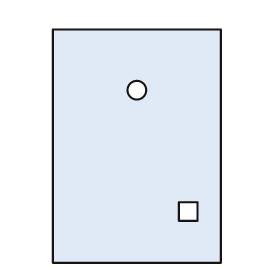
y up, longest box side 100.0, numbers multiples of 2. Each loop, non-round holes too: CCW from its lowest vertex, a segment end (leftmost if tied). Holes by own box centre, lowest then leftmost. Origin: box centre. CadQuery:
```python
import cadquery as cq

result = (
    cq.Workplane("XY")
    .moveTo(-36.0, -50.0)
    .lineTo(36.0, -50.0)
    .lineTo(36.0, 50.0)
    .lineTo(-36.0, 50.0)
    .close()
    .moveTo(18.0, -32.0)
    .lineTo(26.0, -32.0)
    .lineTo(26.0, -24.0)
    .lineTo(18.0, -24.0)
    .close()
    .moveTo(0.0, 24.0)
    .circle(4.0)
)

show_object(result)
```